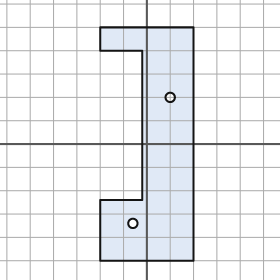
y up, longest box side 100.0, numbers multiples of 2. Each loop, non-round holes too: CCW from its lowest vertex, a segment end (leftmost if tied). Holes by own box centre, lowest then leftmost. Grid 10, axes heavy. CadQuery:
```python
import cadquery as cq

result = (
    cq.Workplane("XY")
    .moveTo(-20.0, -50.0)
    .lineTo(20.0, -50.0)
    .lineTo(20.0, 50.0)
    .lineTo(-20.0, 50.0)
    .lineTo(-20.0, 40.0)
    .lineTo(-2.0, 40.0)
    .lineTo(-2.0, -24.0)
    .lineTo(-20.0, -24.0)
    .close()
    .moveTo(-6.0, -34.0)
    .circle(2.0)
    .moveTo(10.0, 20.0)
    .circle(2.0)
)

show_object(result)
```